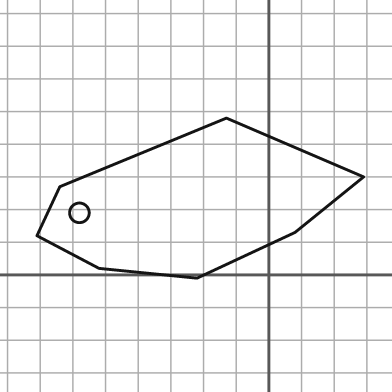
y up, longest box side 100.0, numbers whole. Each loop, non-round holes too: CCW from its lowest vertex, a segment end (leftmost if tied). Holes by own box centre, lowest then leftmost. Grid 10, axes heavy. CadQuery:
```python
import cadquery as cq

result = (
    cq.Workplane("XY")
    .moveTo(-22.0, -1.0)
    .lineTo(8.0, 13.0)
    .lineTo(29.0, 30.0)
    .lineTo(-13.0, 48.0)
    .lineTo(-64.0, 27.0)
    .lineTo(-71.0, 12.0)
    .lineTo(-52.0, 2.0)
    .close()
    .moveTo(-58.0, 19.0)
    .circle(3.0)
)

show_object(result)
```